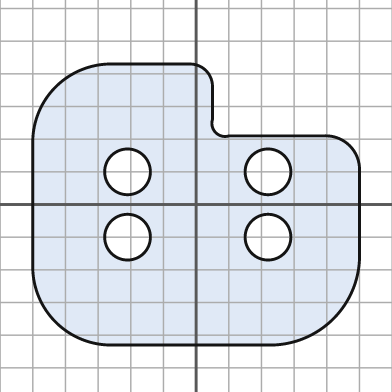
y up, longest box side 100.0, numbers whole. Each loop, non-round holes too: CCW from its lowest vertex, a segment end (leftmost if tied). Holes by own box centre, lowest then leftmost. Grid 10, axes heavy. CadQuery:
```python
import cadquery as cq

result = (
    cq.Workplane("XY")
    .moveTo(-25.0, -43.0)
    .lineTo(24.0, -43.0)
    .threePointArc((42.0, -35.0), (50.0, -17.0))
    .lineTo(50.0, 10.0)
    .threePointArc((47.0, 18.0), (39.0, 21.0))
    .lineTo(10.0, 21.0)
    .threePointArc((6.0, 22.0), (5.0, 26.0))
    .lineTo(5.0, 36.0)
    .threePointArc((3.0, 41.0), (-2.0, 43.0))
    .lineTo(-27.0, 43.0)
    .threePointArc((-43.0, 36.0), (-50.0, 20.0))
    .lineTo(-50.0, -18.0)
    .threePointArc((-43.0, -36.0), (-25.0, -43.0))
    .close()
    .moveTo(-21.0, -10.0)
    .circle(7.0)
    .moveTo(22.0, -10.0)
    .circle(7.0)
    .moveTo(-21.0, 10.0)
    .circle(7.0)
    .moveTo(22.0, 10.0)
    .circle(7.0)
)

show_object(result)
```